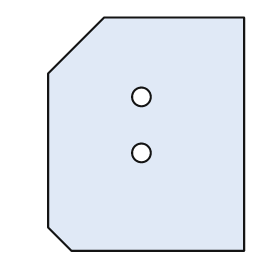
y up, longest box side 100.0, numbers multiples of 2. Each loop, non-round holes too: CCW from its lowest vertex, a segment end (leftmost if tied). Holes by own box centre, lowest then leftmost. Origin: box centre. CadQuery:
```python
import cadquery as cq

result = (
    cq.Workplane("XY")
    .moveTo(-32.0, -50.0)
    .lineTo(42.0, -50.0)
    .lineTo(42.0, 50.0)
    .lineTo(-18.0, 50.0)
    .lineTo(-42.0, 26.0)
    .lineTo(-42.0, -40.0)
    .close()
    .moveTo(-2.0, -8.0)
    .circle(4.0)
    .moveTo(-2.0, 16.0)
    .circle(4.0)
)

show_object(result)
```